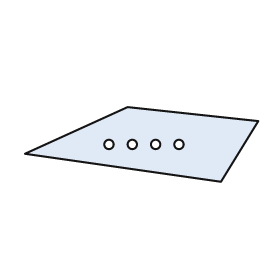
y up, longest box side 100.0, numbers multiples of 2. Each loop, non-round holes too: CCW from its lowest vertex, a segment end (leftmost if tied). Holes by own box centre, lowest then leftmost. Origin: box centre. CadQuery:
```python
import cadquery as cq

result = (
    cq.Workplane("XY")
    .moveTo(34.0, -16.0)
    .lineTo(50.0, 10.0)
    .lineTo(-6.0, 16.0)
    .lineTo(-50.0, -4.0)
    .close()
    .moveTo(-14.0, 0.0)
    .circle(2.0)
    .moveTo(-4.0, 0.0)
    .circle(2.0)
    .moveTo(6.0, 0.0)
    .circle(2.0)
    .moveTo(16.0, 0.0)
    .circle(2.0)
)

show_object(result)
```